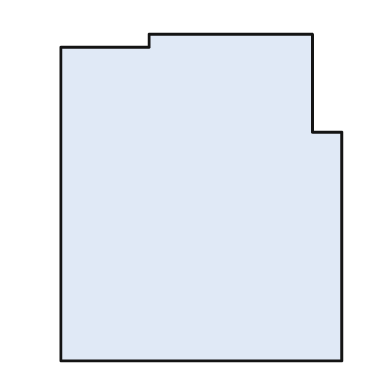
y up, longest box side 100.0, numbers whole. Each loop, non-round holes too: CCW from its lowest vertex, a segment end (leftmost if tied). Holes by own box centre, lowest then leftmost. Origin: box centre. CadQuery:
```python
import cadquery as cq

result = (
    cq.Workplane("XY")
    .moveTo(-43.0, -50.0)
    .lineTo(43.0, -50.0)
    .lineTo(43.0, 20.0)
    .lineTo(34.0, 20.0)
    .lineTo(34.0, 50.0)
    .lineTo(-16.0, 50.0)
    .lineTo(-16.0, 46.0)
    .lineTo(-43.0, 46.0)
    .close()
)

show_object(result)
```